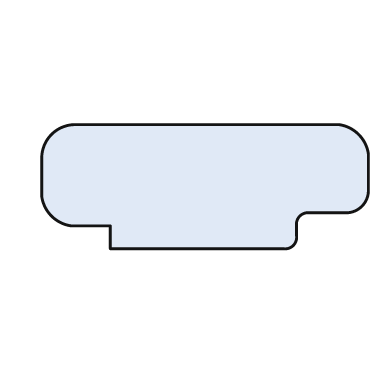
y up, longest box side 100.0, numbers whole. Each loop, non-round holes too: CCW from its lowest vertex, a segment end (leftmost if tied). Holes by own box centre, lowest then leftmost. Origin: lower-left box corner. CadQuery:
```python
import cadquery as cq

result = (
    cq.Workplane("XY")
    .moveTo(21.0, 0.0)
    .lineTo(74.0, 0.0)
    .threePointArc((77.0, 1.0), (78.0, 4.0))
    .lineTo(78.0, 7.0)
    .threePointArc((79.0, 10.0), (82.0, 11.0))
    .lineTo(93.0, 11.0)
    .threePointArc((98.0, 13.0), (100.0, 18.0))
    .lineTo(100.0, 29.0)
    .threePointArc((97.0, 35.0), (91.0, 38.0))
    .lineTo(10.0, 38.0)
    .threePointArc((3.0, 35.0), (0.0, 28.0))
    .lineTo(0.0, 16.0)
    .threePointArc((3.0, 10.0), (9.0, 7.0))
    .lineTo(21.0, 7.0)
    .close()
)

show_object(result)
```